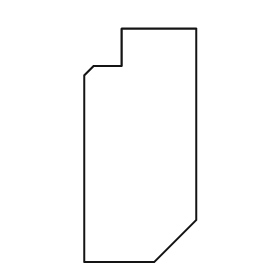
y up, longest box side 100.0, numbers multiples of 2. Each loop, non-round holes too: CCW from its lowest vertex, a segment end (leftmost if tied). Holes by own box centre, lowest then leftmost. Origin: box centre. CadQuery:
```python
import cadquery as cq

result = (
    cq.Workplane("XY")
    .moveTo(-24.0, -50.0)
    .lineTo(6.0, -50.0)
    .lineTo(24.0, -32.0)
    .lineTo(24.0, 50.0)
    .lineTo(-8.0, 50.0)
    .lineTo(-8.0, 34.0)
    .lineTo(-20.0, 34.0)
    .lineTo(-24.0, 30.0)
    .close()
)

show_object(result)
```